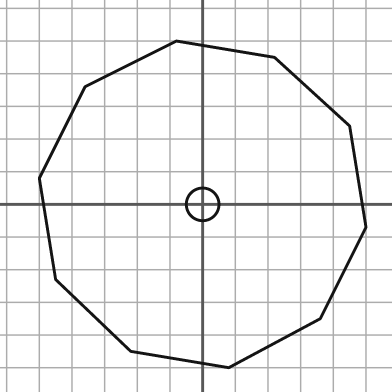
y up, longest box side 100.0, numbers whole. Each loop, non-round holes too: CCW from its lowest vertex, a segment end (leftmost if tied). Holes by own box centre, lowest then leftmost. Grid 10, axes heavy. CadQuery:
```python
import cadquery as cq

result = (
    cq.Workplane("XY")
    .moveTo(8.0, -50.0)
    .lineTo(36.0, -35.0)
    .lineTo(50.0, -7.0)
    .lineTo(45.0, 24.0)
    .lineTo(22.0, 45.0)
    .lineTo(-8.0, 50.0)
    .lineTo(-36.0, 36.0)
    .lineTo(-50.0, 8.0)
    .lineTo(-45.0, -23.0)
    .lineTo(-22.0, -45.0)
    .close()
    .moveTo(0.0, 0.0)
    .circle(5.0)
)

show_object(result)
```